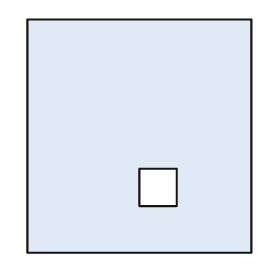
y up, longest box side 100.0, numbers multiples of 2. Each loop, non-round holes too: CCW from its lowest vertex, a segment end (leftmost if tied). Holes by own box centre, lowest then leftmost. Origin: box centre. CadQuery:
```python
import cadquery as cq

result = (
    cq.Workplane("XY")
    .moveTo(-48.0, -50.0)
    .lineTo(48.0, -50.0)
    .lineTo(48.0, 50.0)
    .lineTo(-48.0, 50.0)
    .close()
    .moveTo(0.0, -30.0)
    .lineTo(16.0, -30.0)
    .lineTo(16.0, -14.0)
    .lineTo(0.0, -14.0)
    .close()
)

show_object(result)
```